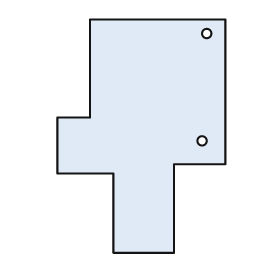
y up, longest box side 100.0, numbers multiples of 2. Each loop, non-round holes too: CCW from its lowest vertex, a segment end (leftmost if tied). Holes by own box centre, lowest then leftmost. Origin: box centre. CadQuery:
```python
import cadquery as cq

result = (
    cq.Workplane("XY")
    .moveTo(-12.0, -50.0)
    .lineTo(14.0, -50.0)
    .lineTo(14.0, -12.0)
    .lineTo(36.0, -12.0)
    .lineTo(36.0, 50.0)
    .lineTo(-22.0, 50.0)
    .lineTo(-22.0, 8.0)
    .lineTo(-36.0, 8.0)
    .lineTo(-36.0, -16.0)
    .lineTo(-12.0, -16.0)
    .close()
    .moveTo(26.0, -2.0)
    .circle(2.0)
    .moveTo(28.0, 44.0)
    .circle(2.0)
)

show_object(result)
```